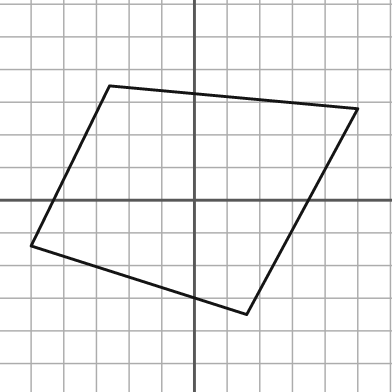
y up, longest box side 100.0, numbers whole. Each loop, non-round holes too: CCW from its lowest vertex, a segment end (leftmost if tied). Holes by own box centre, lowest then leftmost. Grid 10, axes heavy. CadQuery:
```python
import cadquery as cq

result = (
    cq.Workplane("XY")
    .moveTo(16.0, -35.0)
    .lineTo(50.0, 28.0)
    .lineTo(-26.0, 35.0)
    .lineTo(-50.0, -14.0)
    .close()
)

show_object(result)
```